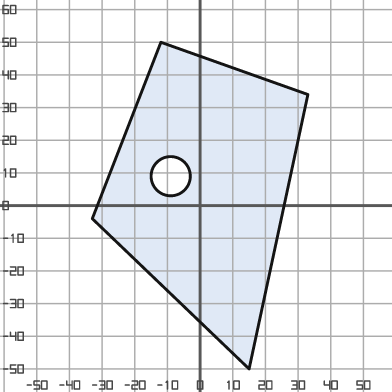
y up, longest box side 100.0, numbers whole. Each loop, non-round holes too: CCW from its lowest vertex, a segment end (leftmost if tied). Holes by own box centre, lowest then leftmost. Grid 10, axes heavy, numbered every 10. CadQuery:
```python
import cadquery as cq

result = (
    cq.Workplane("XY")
    .moveTo(15.0, -50.0)
    .lineTo(33.0, 34.0)
    .lineTo(-12.0, 50.0)
    .lineTo(-33.0, -4.0)
    .close()
    .moveTo(-9.0, 9.0)
    .circle(6.0)
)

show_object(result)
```